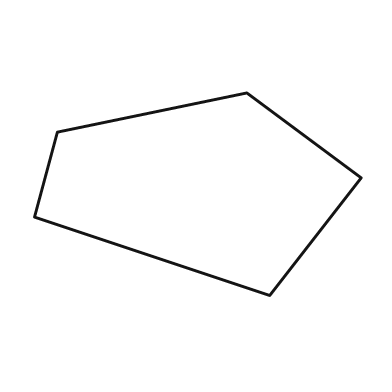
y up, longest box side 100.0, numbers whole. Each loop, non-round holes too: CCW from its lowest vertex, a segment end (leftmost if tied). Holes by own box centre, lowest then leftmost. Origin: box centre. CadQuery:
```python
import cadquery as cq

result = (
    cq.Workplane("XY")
    .moveTo(22.0, -31.0)
    .lineTo(50.0, 5.0)
    .lineTo(15.0, 31.0)
    .lineTo(-43.0, 19.0)
    .lineTo(-50.0, -7.0)
    .close()
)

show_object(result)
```